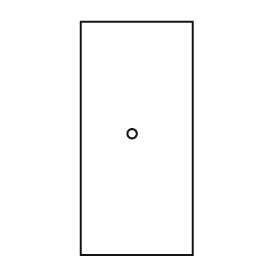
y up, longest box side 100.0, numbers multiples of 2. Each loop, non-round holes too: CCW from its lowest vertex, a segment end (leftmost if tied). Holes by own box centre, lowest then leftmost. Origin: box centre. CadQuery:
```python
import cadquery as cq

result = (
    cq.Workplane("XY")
    .moveTo(-24.0, -50.0)
    .lineTo(24.0, -50.0)
    .lineTo(24.0, 50.0)
    .lineTo(-24.0, 50.0)
    .close()
    .moveTo(-2.0, 2.0)
    .circle(2.0)
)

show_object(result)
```